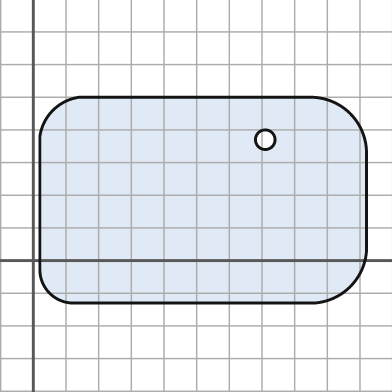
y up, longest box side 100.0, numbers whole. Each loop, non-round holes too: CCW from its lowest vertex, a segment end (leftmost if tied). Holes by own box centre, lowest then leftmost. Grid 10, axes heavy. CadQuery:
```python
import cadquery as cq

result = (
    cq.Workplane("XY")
    .moveTo(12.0, -13.0)
    .lineTo(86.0, -13.0)
    .threePointArc((97.0, -8.0), (102.0, 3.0))
    .lineTo(102.0, 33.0)
    .threePointArc((97.0, 45.0), (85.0, 50.0))
    .lineTo(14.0, 50.0)
    .threePointArc((6.0, 46.0), (2.0, 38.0))
    .lineTo(2.0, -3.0)
    .threePointArc((5.0, -10.0), (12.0, -13.0))
    .close()
    .moveTo(71.0, 37.0)
    .circle(3.0)
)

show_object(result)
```